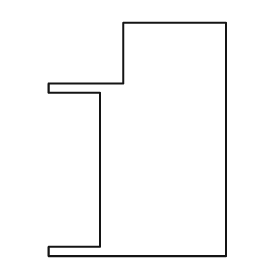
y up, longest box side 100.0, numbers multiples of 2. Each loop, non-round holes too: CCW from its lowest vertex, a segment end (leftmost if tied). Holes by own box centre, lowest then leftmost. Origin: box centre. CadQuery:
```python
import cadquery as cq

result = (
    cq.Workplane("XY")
    .moveTo(-38.0, -50.0)
    .lineTo(38.0, -50.0)
    .lineTo(38.0, 50.0)
    .lineTo(-6.0, 50.0)
    .lineTo(-6.0, 24.0)
    .lineTo(-38.0, 24.0)
    .lineTo(-38.0, 20.0)
    .lineTo(-16.0, 20.0)
    .lineTo(-16.0, -46.0)
    .lineTo(-38.0, -46.0)
    .close()
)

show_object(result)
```